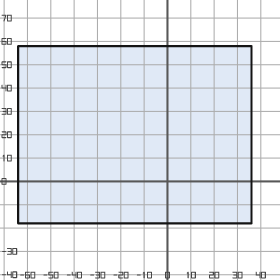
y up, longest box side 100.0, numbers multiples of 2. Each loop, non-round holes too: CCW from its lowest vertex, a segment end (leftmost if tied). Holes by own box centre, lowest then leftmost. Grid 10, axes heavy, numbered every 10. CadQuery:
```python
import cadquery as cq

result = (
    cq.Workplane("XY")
    .moveTo(-64.0, -18.0)
    .lineTo(36.0, -18.0)
    .lineTo(36.0, 58.0)
    .lineTo(-64.0, 58.0)
    .close()
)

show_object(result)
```